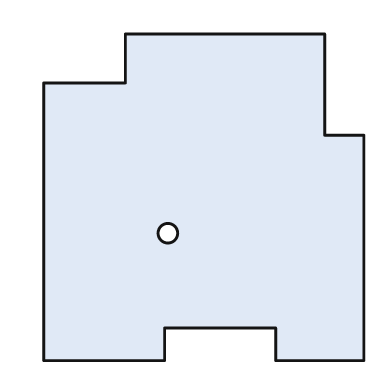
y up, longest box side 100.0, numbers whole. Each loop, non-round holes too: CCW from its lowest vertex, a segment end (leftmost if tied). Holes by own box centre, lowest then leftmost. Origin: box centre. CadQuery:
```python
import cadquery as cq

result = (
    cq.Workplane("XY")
    .moveTo(-49.0, -50.0)
    .lineTo(-12.0, -50.0)
    .lineTo(-12.0, -40.0)
    .lineTo(22.0, -40.0)
    .lineTo(22.0, -50.0)
    .lineTo(49.0, -50.0)
    .lineTo(49.0, 19.0)
    .lineTo(37.0, 19.0)
    .lineTo(37.0, 50.0)
    .lineTo(-24.0, 50.0)
    .lineTo(-24.0, 35.0)
    .lineTo(-49.0, 35.0)
    .close()
    .moveTo(-11.0, -11.0)
    .circle(3.0)
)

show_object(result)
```